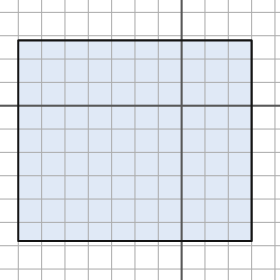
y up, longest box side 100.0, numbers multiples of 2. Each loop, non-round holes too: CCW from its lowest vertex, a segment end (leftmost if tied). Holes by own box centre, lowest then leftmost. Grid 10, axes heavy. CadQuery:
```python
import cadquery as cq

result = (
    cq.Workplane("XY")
    .moveTo(-70.0, -58.0)
    .lineTo(30.0, -58.0)
    .lineTo(30.0, 28.0)
    .lineTo(-70.0, 28.0)
    .close()
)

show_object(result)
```